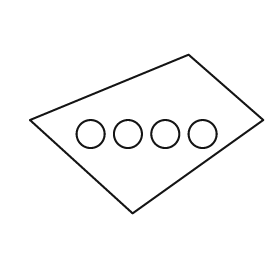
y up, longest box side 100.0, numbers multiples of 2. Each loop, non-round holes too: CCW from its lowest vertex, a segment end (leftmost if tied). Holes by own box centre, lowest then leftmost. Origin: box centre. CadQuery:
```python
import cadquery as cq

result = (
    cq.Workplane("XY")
    .moveTo(-6.0, -34.0)
    .lineTo(50.0, 6.0)
    .lineTo(18.0, 34.0)
    .lineTo(-50.0, 6.0)
    .close()
    .moveTo(-24.0, 0.0)
    .circle(6.0)
    .moveTo(-8.0, 0.0)
    .circle(6.0)
    .moveTo(8.0, 0.0)
    .circle(6.0)
    .moveTo(24.0, 0.0)
    .circle(6.0)
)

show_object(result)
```